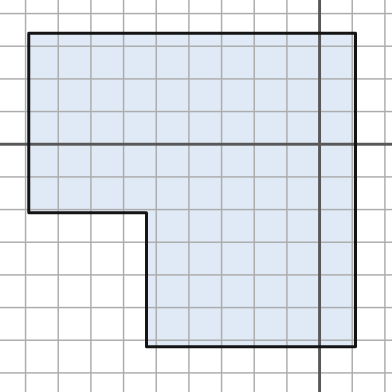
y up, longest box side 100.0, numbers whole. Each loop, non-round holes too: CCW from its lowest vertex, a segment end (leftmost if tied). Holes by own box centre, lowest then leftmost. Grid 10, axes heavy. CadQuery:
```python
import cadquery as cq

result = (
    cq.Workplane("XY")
    .moveTo(-53.0, -62.0)
    .lineTo(11.0, -62.0)
    .lineTo(11.0, 34.0)
    .lineTo(-89.0, 34.0)
    .lineTo(-89.0, -21.0)
    .lineTo(-53.0, -21.0)
    .close()
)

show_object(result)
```